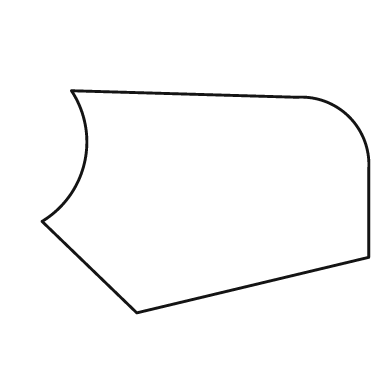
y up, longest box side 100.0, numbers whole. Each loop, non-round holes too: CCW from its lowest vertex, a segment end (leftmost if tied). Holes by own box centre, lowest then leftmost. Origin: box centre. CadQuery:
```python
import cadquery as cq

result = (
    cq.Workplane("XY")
    .moveTo(-21.0, -34.0)
    .lineTo(50.0, -17.0)
    .lineTo(50.0, 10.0)
    .threePointArc((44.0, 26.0), (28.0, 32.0))
    .lineTo(-41.0, 34.0)
    .threePointArc((-37.0, 12.0), (-50.0, -6.0))
    .close()
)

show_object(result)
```